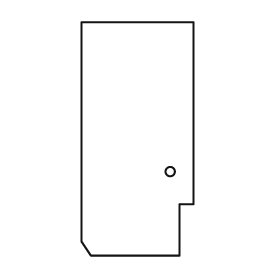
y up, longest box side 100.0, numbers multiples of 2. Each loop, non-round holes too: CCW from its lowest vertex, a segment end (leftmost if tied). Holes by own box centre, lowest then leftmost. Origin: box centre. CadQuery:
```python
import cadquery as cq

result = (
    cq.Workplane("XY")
    .moveTo(-20.0, -50.0)
    .lineTo(18.0, -50.0)
    .lineTo(18.0, -28.0)
    .lineTo(24.0, -28.0)
    .lineTo(24.0, 50.0)
    .lineTo(-24.0, 50.0)
    .lineTo(-24.0, -44.0)
    .close()
    .moveTo(14.0, -14.0)
    .circle(2.0)
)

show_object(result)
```